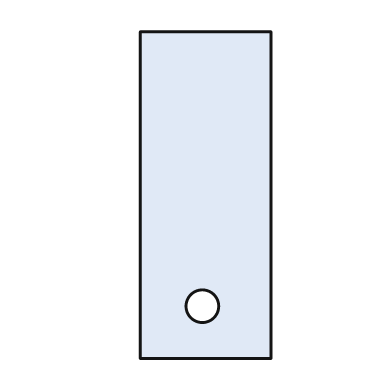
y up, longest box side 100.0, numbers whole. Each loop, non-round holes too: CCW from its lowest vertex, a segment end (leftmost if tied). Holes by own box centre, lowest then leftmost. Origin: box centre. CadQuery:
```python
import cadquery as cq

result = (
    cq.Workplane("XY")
    .moveTo(-20.0, -50.0)
    .lineTo(20.0, -50.0)
    .lineTo(20.0, 50.0)
    .lineTo(-20.0, 50.0)
    .close()
    .moveTo(-1.0, -34.0)
    .circle(5.0)
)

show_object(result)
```